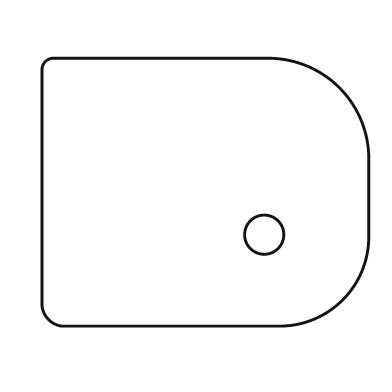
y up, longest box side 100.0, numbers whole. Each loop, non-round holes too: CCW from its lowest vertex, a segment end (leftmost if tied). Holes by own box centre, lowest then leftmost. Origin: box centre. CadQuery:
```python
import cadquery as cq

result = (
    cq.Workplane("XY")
    .moveTo(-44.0, -41.0)
    .lineTo(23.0, -41.0)
    .threePointArc((42.0, -33.0), (50.0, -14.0))
    .lineTo(50.0, 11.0)
    .threePointArc((41.0, 32.0), (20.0, 41.0))
    .lineTo(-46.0, 41.0)
    .threePointArc((-49.0, 40.0), (-50.0, 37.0))
    .lineTo(-50.0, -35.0)
    .threePointArc((-48.0, -39.0), (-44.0, -41.0))
    .close()
    .moveTo(18.0, -13.0)
    .circle(6.0)
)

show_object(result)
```